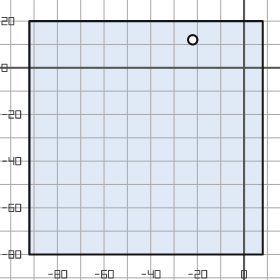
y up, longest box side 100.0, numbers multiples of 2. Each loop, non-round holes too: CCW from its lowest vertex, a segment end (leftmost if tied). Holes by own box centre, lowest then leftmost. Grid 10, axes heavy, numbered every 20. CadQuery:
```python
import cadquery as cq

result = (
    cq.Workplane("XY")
    .moveTo(-92.0, -80.0)
    .lineTo(8.0, -80.0)
    .lineTo(8.0, 20.0)
    .lineTo(-92.0, 20.0)
    .close()
    .moveTo(-22.0, 12.0)
    .circle(2.0)
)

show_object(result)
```